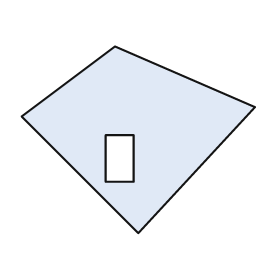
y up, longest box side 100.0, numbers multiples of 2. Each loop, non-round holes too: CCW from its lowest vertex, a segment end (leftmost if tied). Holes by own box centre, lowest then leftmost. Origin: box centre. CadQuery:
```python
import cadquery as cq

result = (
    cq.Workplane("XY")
    .moveTo(0.0, -40.0)
    .lineTo(50.0, 14.0)
    .lineTo(-10.0, 40.0)
    .lineTo(-50.0, 10.0)
    .close()
    .moveTo(-14.0, -18.0)
    .lineTo(-2.0, -18.0)
    .lineTo(-2.0, 2.0)
    .lineTo(-14.0, 2.0)
    .close()
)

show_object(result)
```